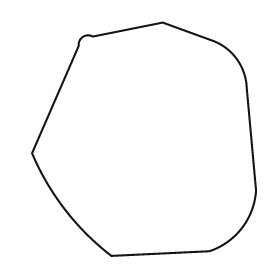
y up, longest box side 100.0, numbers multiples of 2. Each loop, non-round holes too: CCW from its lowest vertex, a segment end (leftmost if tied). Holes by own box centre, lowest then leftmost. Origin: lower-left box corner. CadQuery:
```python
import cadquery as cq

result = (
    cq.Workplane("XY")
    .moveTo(34.0, 0.0)
    .lineTo(76.0, 2.0)
    .threePointArc((90.0, 12.0), (96.0, 28.0))
    .lineTo(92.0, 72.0)
    .threePointArc((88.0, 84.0), (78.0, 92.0))
    .lineTo(56.0, 100.0)
    .lineTo(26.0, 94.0)
    .threePointArc((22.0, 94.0), (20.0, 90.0))
    .lineTo(0.0, 44.0)
    .threePointArc((14.0, 20.0), (34.0, 0.0))
    .close()
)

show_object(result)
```